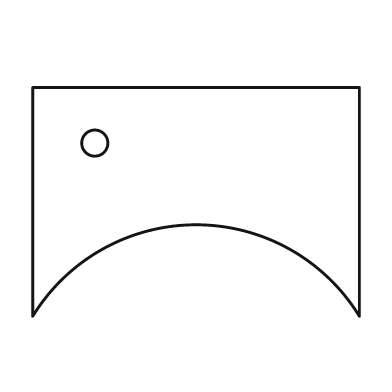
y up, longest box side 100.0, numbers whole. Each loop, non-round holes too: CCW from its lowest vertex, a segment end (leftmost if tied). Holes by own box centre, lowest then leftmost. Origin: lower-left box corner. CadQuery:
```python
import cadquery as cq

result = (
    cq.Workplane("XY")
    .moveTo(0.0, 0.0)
    .threePointArc((50.0, 28.0), (100.0, 0.0))
    .lineTo(100.0, 70.0)
    .lineTo(0.0, 70.0)
    .close()
    .moveTo(19.0, 53.0)
    .circle(4.0)
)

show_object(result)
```